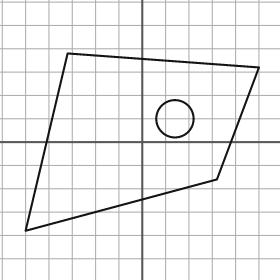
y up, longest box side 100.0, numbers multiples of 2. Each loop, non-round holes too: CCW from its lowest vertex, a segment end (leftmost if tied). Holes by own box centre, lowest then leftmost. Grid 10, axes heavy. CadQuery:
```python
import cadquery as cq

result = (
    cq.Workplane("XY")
    .moveTo(-50.0, -38.0)
    .lineTo(32.0, -16.0)
    .lineTo(50.0, 32.0)
    .lineTo(-32.0, 38.0)
    .close()
    .moveTo(14.0, 10.0)
    .circle(8.0)
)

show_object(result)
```